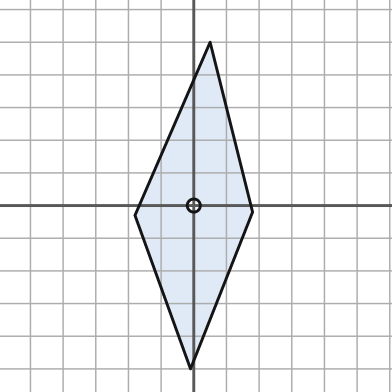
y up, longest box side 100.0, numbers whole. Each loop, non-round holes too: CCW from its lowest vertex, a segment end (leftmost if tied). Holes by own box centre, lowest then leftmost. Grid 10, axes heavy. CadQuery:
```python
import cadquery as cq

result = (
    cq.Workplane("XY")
    .moveTo(-1.0, -50.0)
    .lineTo(18.0, -2.0)
    .lineTo(5.0, 50.0)
    .lineTo(-18.0, -3.0)
    .close()
    .moveTo(0.0, 0.0)
    .circle(2.0)
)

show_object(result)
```